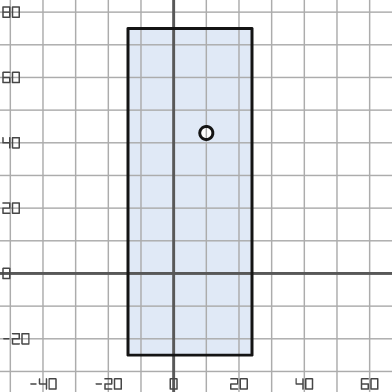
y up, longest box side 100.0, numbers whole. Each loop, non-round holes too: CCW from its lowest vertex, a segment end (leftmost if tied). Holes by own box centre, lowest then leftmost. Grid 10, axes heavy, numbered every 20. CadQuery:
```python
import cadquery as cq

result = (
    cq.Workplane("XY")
    .moveTo(-14.0, -25.0)
    .lineTo(24.0, -25.0)
    .lineTo(24.0, 75.0)
    .lineTo(-14.0, 75.0)
    .close()
    .moveTo(10.0, 43.0)
    .circle(2.0)
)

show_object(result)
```